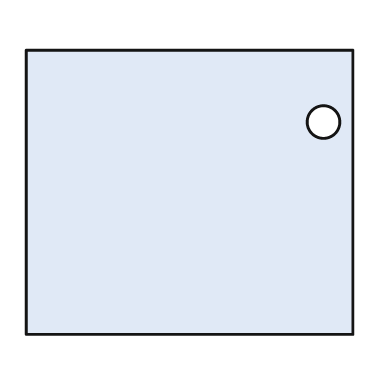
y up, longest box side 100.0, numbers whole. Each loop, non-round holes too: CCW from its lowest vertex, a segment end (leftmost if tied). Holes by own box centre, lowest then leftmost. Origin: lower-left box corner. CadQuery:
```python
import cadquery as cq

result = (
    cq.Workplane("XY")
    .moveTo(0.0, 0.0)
    .lineTo(100.0, 0.0)
    .lineTo(100.0, 87.0)
    .lineTo(0.0, 87.0)
    .close()
    .moveTo(91.0, 65.0)
    .circle(5.0)
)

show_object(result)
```